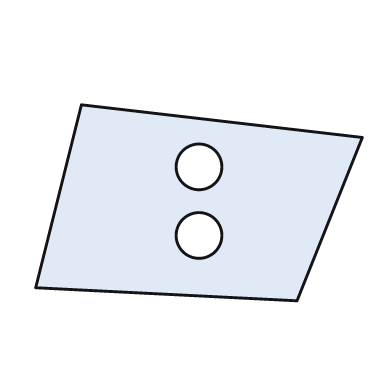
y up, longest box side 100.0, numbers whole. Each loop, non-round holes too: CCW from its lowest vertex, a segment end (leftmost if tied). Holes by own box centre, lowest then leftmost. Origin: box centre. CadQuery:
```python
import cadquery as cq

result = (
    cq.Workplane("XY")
    .moveTo(30.0, -30.0)
    .lineTo(50.0, 20.0)
    .lineTo(-36.0, 30.0)
    .lineTo(-50.0, -26.0)
    .close()
    .moveTo(0.0, -10.0)
    .circle(7.0)
    .moveTo(0.0, 11.0)
    .circle(7.0)
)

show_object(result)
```